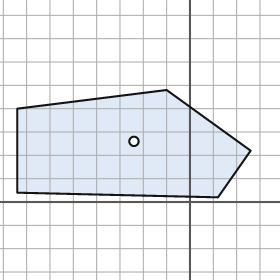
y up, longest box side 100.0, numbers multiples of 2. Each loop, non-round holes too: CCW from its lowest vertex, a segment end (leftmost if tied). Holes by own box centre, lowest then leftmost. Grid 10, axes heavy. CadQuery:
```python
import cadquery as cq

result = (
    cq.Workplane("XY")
    .moveTo(12.0, 2.0)
    .lineTo(26.0, 22.0)
    .lineTo(-10.0, 48.0)
    .lineTo(-74.0, 40.0)
    .lineTo(-74.0, 4.0)
    .close()
    .moveTo(-24.0, 26.0)
    .circle(2.0)
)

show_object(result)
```